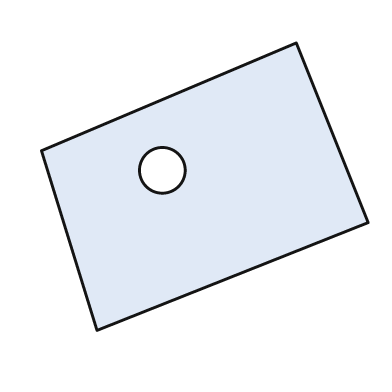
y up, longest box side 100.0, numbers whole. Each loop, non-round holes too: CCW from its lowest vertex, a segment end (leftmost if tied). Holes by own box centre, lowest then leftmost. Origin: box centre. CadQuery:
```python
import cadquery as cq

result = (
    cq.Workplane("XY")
    .moveTo(-33.0, -44.0)
    .lineTo(50.0, -11.0)
    .lineTo(28.0, 44.0)
    .lineTo(-50.0, 11.0)
    .close()
    .moveTo(-13.0, 5.0)
    .circle(7.0)
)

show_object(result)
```